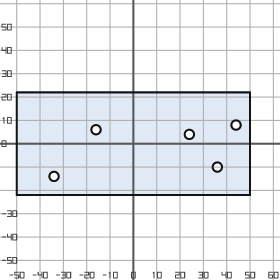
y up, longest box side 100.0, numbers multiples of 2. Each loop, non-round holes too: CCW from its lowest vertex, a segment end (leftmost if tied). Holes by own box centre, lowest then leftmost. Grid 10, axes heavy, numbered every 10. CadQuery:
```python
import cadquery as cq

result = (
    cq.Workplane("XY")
    .moveTo(-50.0, -22.0)
    .lineTo(50.0, -22.0)
    .lineTo(50.0, 22.0)
    .lineTo(-50.0, 22.0)
    .close()
    .moveTo(-34.0, -14.0)
    .circle(2.0)
    .moveTo(36.0, -10.0)
    .circle(2.0)
    .moveTo(24.0, 4.0)
    .circle(2.0)
    .moveTo(-16.0, 6.0)
    .circle(2.0)
    .moveTo(44.0, 8.0)
    .circle(2.0)
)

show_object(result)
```